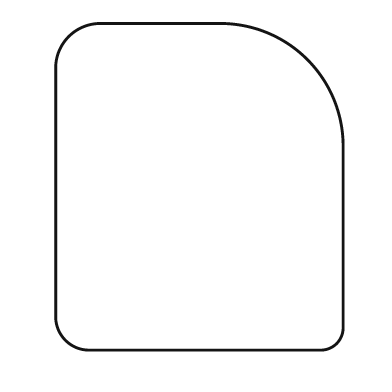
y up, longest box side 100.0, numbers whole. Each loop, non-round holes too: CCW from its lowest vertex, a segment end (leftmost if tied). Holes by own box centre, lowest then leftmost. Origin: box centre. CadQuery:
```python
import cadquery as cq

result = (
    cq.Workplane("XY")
    .moveTo(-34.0, -50.0)
    .lineTo(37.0, -50.0)
    .threePointArc((42.0, -48.0), (44.0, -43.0))
    .lineTo(44.0, 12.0)
    .threePointArc((33.0, 39.0), (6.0, 50.0))
    .lineTo(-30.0, 50.0)
    .threePointArc((-40.0, 46.0), (-44.0, 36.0))
    .lineTo(-44.0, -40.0)
    .threePointArc((-41.0, -47.0), (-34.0, -50.0))
    .close()
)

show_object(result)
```